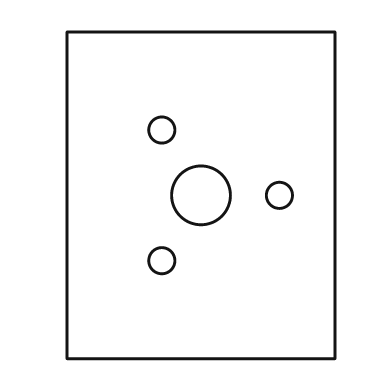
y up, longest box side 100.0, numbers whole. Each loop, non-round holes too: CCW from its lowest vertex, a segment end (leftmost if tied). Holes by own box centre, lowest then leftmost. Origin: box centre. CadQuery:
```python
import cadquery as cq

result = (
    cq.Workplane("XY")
    .moveTo(-41.0, -50.0)
    .lineTo(41.0, -50.0)
    .lineTo(41.0, 50.0)
    .lineTo(-41.0, 50.0)
    .close()
    .moveTo(-12.0, -20.0)
    .circle(4.0)
    .moveTo(0.0, 0.0)
    .circle(9.0)
    .moveTo(24.0, 0.0)
    .circle(4.0)
    .moveTo(-12.0, 20.0)
    .circle(4.0)
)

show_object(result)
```